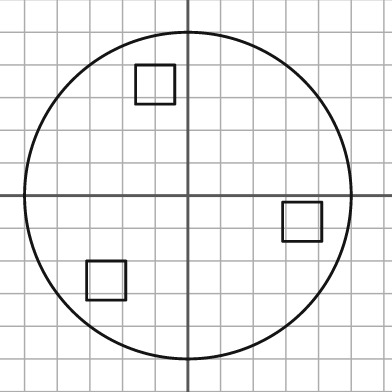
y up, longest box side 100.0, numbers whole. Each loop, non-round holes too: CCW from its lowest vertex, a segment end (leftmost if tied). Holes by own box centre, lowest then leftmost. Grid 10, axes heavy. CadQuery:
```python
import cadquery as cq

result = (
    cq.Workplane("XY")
    .moveTo(0.0, 0.0)
    .circle(50.0)
    .moveTo(-31.0, -32.0)
    .lineTo(-19.0, -32.0)
    .lineTo(-19.0, -20.0)
    .lineTo(-31.0, -20.0)
    .close()
    .moveTo(29.0, -14.0)
    .lineTo(41.0, -14.0)
    .lineTo(41.0, -2.0)
    .lineTo(29.0, -2.0)
    .close()
    .moveTo(-16.0, 28.0)
    .lineTo(-4.0, 28.0)
    .lineTo(-4.0, 40.0)
    .lineTo(-16.0, 40.0)
    .close()
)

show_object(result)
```